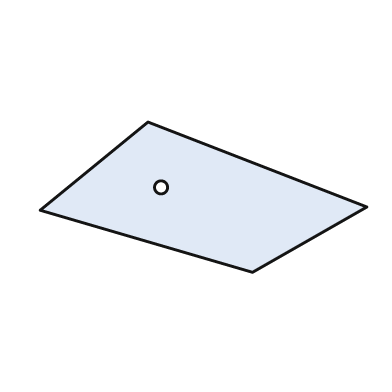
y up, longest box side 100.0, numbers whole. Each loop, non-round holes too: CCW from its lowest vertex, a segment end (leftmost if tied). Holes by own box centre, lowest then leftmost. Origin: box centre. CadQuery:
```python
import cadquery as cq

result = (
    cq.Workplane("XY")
    .moveTo(15.0, -23.0)
    .lineTo(50.0, -3.0)
    .lineTo(-17.0, 23.0)
    .lineTo(-50.0, -4.0)
    .close()
    .moveTo(-13.0, 3.0)
    .circle(2.0)
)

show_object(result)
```